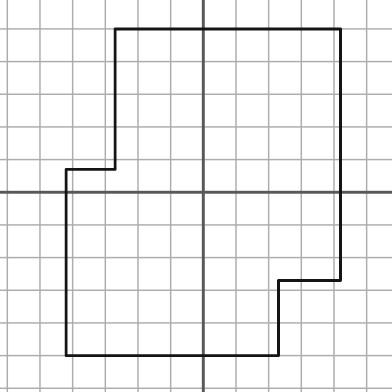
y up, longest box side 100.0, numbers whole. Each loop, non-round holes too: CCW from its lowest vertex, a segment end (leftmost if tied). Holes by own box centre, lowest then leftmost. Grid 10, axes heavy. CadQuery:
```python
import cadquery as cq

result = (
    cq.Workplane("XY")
    .moveTo(-42.0, -50.0)
    .lineTo(23.0, -50.0)
    .lineTo(23.0, -27.0)
    .lineTo(42.0, -27.0)
    .lineTo(42.0, 50.0)
    .lineTo(-27.0, 50.0)
    .lineTo(-27.0, 7.0)
    .lineTo(-42.0, 7.0)
    .close()
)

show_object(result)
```